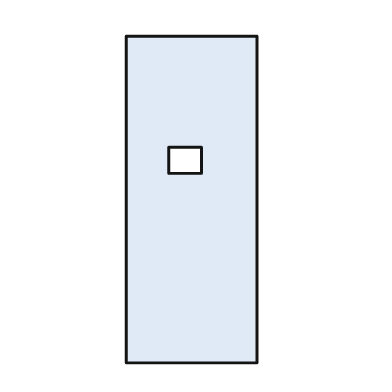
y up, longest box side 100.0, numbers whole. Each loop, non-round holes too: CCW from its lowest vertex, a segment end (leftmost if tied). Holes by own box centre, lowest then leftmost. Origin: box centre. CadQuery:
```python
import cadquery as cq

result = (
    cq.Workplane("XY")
    .moveTo(-20.0, -50.0)
    .lineTo(20.0, -50.0)
    .lineTo(20.0, 50.0)
    .lineTo(-20.0, 50.0)
    .close()
    .moveTo(-7.0, 8.0)
    .lineTo(3.0, 8.0)
    .lineTo(3.0, 16.0)
    .lineTo(-7.0, 16.0)
    .close()
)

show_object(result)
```